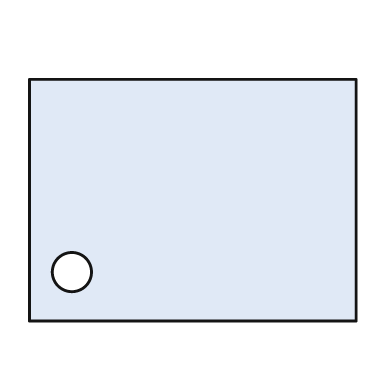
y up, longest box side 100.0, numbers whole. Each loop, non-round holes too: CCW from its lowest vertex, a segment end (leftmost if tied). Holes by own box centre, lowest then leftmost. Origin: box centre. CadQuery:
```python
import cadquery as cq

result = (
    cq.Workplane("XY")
    .moveTo(-50.0, -37.0)
    .lineTo(50.0, -37.0)
    .lineTo(50.0, 37.0)
    .lineTo(-50.0, 37.0)
    .close()
    .moveTo(-37.0, -22.0)
    .circle(6.0)
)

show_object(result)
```